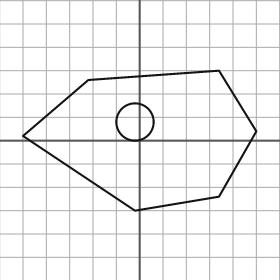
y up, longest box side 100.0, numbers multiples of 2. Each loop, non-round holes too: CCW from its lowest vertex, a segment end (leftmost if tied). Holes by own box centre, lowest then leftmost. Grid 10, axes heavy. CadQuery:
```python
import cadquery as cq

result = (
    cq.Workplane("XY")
    .moveTo(-2.0, -30.0)
    .lineTo(34.0, -24.0)
    .lineTo(50.0, 4.0)
    .lineTo(34.0, 30.0)
    .lineTo(-22.0, 26.0)
    .lineTo(-50.0, 2.0)
    .close()
    .moveTo(-2.0, 8.0)
    .circle(8.0)
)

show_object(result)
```